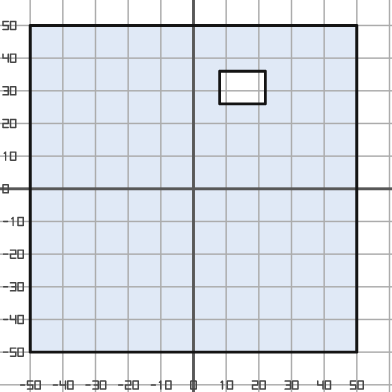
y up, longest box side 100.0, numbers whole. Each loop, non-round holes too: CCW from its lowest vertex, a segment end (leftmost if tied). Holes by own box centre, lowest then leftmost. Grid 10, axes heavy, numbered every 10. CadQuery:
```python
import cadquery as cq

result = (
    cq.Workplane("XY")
    .moveTo(-50.0, -50.0)
    .lineTo(50.0, -50.0)
    .lineTo(50.0, 50.0)
    .lineTo(-50.0, 50.0)
    .close()
    .moveTo(8.0, 26.0)
    .lineTo(22.0, 26.0)
    .lineTo(22.0, 36.0)
    .lineTo(8.0, 36.0)
    .close()
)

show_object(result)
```